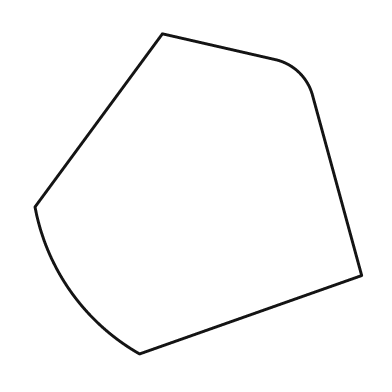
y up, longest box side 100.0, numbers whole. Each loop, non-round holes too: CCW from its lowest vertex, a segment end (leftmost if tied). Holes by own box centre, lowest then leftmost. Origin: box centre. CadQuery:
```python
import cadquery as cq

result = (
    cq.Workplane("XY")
    .moveTo(-18.0, -49.0)
    .lineTo(50.0, -25.0)
    .lineTo(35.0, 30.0)
    .threePointArc((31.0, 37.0), (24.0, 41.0))
    .lineTo(-11.0, 49.0)
    .lineTo(-50.0, -4.0)
    .threePointArc((-39.0, -30.0), (-18.0, -49.0))
    .close()
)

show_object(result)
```